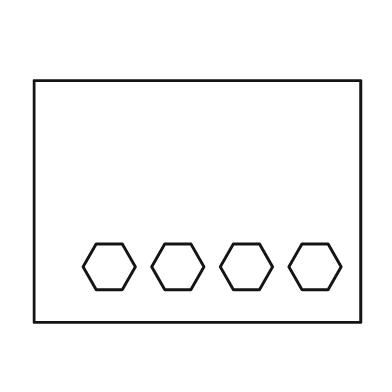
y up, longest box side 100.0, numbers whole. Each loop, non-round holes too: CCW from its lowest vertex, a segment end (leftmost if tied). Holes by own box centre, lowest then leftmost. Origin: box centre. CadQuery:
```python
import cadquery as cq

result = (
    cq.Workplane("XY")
    .moveTo(-50.0, -37.0)
    .lineTo(50.0, -37.0)
    .lineTo(50.0, 37.0)
    .lineTo(-50.0, 37.0)
    .close()
    .moveTo(-31.0, -27.0)
    .lineTo(-23.0, -27.0)
    .lineTo(-19.0, -20.0)
    .lineTo(-23.0, -13.0)
    .lineTo(-31.0, -13.0)
    .lineTo(-35.0, -20.0)
    .close()
    .moveTo(-10.0, -27.0)
    .lineTo(-2.0, -27.0)
    .lineTo(2.0, -20.0)
    .lineTo(-2.0, -13.0)
    .lineTo(-10.0, -13.0)
    .lineTo(-14.0, -20.0)
    .close()
    .moveTo(11.0, -27.0)
    .lineTo(19.0, -27.0)
    .lineTo(23.0, -20.0)
    .lineTo(19.0, -13.0)
    .lineTo(11.0, -13.0)
    .lineTo(7.0, -20.0)
    .close()
    .moveTo(32.0, -27.0)
    .lineTo(40.0, -27.0)
    .lineTo(44.0, -20.0)
    .lineTo(40.0, -13.0)
    .lineTo(32.0, -13.0)
    .lineTo(28.0, -20.0)
    .close()
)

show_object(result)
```